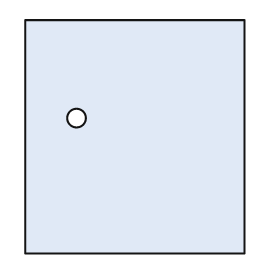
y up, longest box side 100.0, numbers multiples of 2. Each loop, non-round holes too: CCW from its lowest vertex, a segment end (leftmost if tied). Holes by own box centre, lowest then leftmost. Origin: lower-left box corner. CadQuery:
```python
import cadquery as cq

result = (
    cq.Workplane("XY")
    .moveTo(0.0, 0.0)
    .lineTo(94.0, 0.0)
    .lineTo(94.0, 100.0)
    .lineTo(0.0, 100.0)
    .close()
    .moveTo(22.0, 58.0)
    .circle(4.0)
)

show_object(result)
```